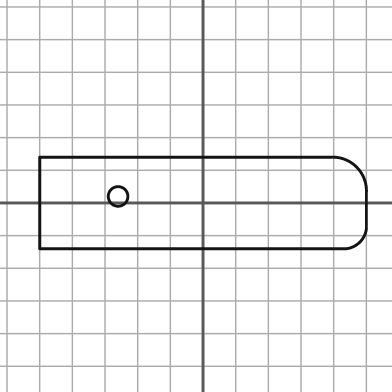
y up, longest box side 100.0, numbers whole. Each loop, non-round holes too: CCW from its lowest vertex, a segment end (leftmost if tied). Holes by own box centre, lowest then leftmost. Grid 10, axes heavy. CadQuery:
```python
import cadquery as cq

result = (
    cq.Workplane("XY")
    .moveTo(-50.0, -14.0)
    .lineTo(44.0, -14.0)
    .threePointArc((48.0, -12.0), (50.0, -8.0))
    .lineTo(50.0, 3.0)
    .threePointArc((47.0, 11.0), (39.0, 14.0))
    .lineTo(-50.0, 14.0)
    .close()
    .moveTo(-26.0, 2.0)
    .circle(3.0)
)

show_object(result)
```